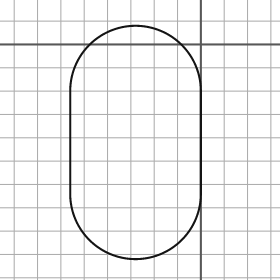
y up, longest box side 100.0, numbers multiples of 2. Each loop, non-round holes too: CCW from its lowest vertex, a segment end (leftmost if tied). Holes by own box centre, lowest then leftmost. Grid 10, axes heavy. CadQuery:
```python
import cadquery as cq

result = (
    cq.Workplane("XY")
    .moveTo(-56.0, -64.0)
    .threePointArc((-28.0, -92.0), (0.0, -64.0))
    .lineTo(0.0, -20.0)
    .threePointArc((-28.0, 8.0), (-56.0, -20.0))
    .close()
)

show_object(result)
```